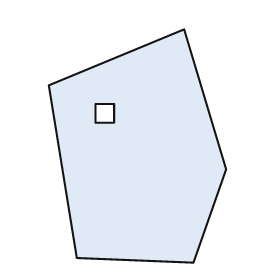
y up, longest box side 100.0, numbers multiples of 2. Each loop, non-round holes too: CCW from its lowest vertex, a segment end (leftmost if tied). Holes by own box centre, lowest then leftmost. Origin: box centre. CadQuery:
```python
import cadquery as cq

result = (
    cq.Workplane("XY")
    .moveTo(24.0, -50.0)
    .lineTo(38.0, -10.0)
    .lineTo(20.0, 50.0)
    .lineTo(-38.0, 26.0)
    .lineTo(-26.0, -48.0)
    .close()
    .moveTo(-18.0, 10.0)
    .lineTo(-10.0, 10.0)
    .lineTo(-10.0, 18.0)
    .lineTo(-18.0, 18.0)
    .close()
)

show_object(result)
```